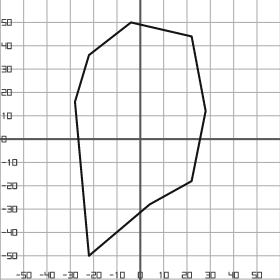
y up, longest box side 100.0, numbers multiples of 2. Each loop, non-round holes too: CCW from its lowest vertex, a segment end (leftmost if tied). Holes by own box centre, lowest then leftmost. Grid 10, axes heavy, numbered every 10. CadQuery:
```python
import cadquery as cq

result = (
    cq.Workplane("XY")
    .moveTo(-22.0, -50.0)
    .lineTo(4.0, -28.0)
    .lineTo(22.0, -18.0)
    .lineTo(28.0, 12.0)
    .lineTo(22.0, 44.0)
    .lineTo(-4.0, 50.0)
    .lineTo(-22.0, 36.0)
    .lineTo(-28.0, 16.0)
    .close()
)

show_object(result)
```